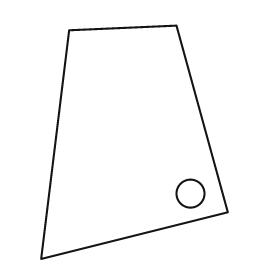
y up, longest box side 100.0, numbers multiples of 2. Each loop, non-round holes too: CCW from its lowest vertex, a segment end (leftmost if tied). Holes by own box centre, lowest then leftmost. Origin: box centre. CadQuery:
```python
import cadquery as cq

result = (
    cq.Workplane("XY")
    .moveTo(-40.0, -50.0)
    .lineTo(40.0, -30.0)
    .lineTo(18.0, 50.0)
    .lineTo(-28.0, 48.0)
    .close()
    .moveTo(24.0, -22.0)
    .circle(6.0)
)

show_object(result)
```